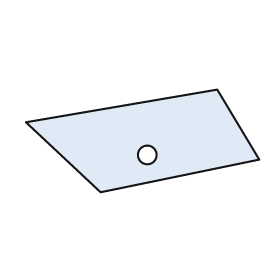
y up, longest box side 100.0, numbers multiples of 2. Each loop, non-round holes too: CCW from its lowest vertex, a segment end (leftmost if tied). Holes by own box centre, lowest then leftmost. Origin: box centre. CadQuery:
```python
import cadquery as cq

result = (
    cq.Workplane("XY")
    .moveTo(-18.0, -22.0)
    .lineTo(50.0, -8.0)
    .lineTo(32.0, 22.0)
    .lineTo(-50.0, 8.0)
    .close()
    .moveTo(2.0, -6.0)
    .circle(4.0)
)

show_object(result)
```